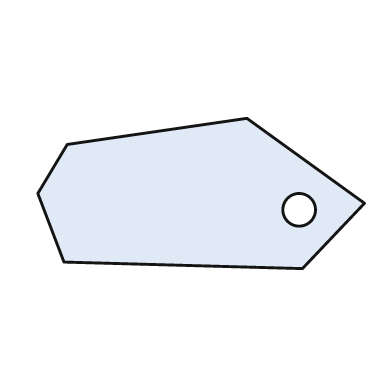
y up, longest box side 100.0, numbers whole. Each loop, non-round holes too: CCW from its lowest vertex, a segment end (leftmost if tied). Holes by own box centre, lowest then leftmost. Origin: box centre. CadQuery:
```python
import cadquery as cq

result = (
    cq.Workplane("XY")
    .moveTo(31.0, -23.0)
    .lineTo(50.0, -3.0)
    .lineTo(14.0, 23.0)
    .lineTo(-41.0, 15.0)
    .lineTo(-50.0, 0.0)
    .lineTo(-42.0, -21.0)
    .close()
    .moveTo(30.0, -5.0)
    .circle(5.0)
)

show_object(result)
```